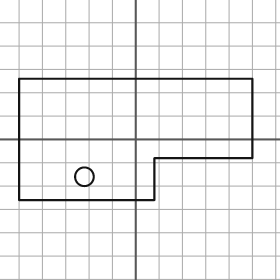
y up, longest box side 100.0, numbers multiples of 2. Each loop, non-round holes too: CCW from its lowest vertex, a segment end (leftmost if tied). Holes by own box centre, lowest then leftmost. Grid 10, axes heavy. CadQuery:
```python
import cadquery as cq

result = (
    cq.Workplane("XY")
    .moveTo(-50.0, -26.0)
    .lineTo(8.0, -26.0)
    .lineTo(8.0, -8.0)
    .lineTo(50.0, -8.0)
    .lineTo(50.0, 26.0)
    .lineTo(-50.0, 26.0)
    .close()
    .moveTo(-22.0, -16.0)
    .circle(4.0)
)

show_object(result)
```